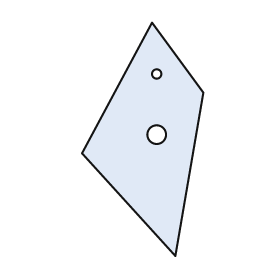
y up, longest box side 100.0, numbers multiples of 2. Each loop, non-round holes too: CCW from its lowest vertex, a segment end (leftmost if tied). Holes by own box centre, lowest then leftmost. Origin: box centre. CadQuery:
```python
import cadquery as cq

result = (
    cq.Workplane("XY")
    .moveTo(14.0, -50.0)
    .lineTo(26.0, 20.0)
    .lineTo(4.0, 50.0)
    .lineTo(-26.0, -6.0)
    .close()
    .moveTo(6.0, 2.0)
    .circle(4.0)
    .moveTo(6.0, 28.0)
    .circle(2.0)
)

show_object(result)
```